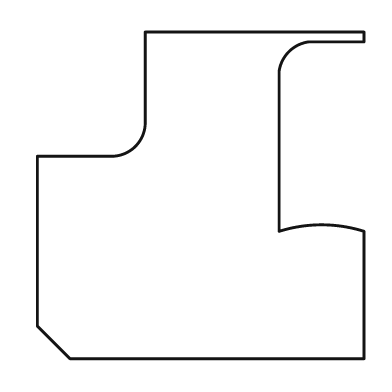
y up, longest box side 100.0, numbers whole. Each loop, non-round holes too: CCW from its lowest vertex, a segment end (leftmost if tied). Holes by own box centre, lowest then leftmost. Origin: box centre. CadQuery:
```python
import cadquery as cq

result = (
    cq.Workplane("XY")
    .moveTo(-40.0, -50.0)
    .lineTo(50.0, -50.0)
    .lineTo(50.0, -11.0)
    .threePointArc((37.0, -9.0), (24.0, -11.0))
    .lineTo(24.0, 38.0)
    .threePointArc((27.0, 44.0), (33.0, 47.0))
    .lineTo(50.0, 47.0)
    .lineTo(50.0, 50.0)
    .lineTo(-17.0, 50.0)
    .lineTo(-17.0, 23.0)
    .threePointArc((-20.0, 15.0), (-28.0, 12.0))
    .lineTo(-50.0, 12.0)
    .lineTo(-50.0, -40.0)
    .close()
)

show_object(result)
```